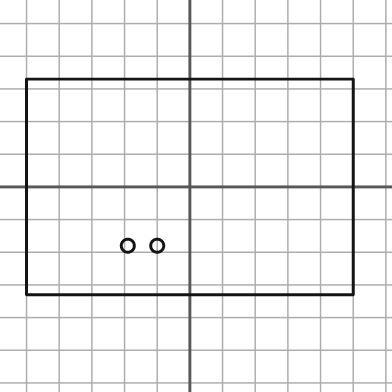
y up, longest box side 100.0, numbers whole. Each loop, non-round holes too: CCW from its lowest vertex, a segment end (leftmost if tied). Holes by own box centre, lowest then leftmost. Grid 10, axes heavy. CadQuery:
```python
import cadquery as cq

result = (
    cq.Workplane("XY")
    .moveTo(-50.0, -33.0)
    .lineTo(50.0, -33.0)
    .lineTo(50.0, 33.0)
    .lineTo(-50.0, 33.0)
    .close()
    .moveTo(-19.0, -18.0)
    .circle(2.0)
    .moveTo(-10.0, -18.0)
    .circle(2.0)
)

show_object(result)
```